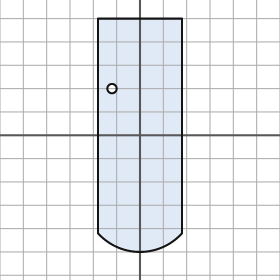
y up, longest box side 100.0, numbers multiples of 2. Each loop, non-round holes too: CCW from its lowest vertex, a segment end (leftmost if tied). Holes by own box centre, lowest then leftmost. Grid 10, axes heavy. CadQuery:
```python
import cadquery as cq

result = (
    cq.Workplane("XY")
    .moveTo(-18.0, -42.0)
    .threePointArc((0.0, -50.0), (18.0, -42.0))
    .lineTo(18.0, 50.0)
    .lineTo(-18.0, 50.0)
    .close()
    .moveTo(-12.0, 20.0)
    .circle(2.0)
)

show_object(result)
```